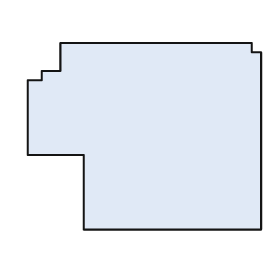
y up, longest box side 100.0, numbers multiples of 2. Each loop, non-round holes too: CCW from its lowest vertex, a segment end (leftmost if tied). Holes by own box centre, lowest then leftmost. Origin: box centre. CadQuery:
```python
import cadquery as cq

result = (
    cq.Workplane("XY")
    .moveTo(-26.0, -40.0)
    .lineTo(50.0, -40.0)
    .lineTo(50.0, 36.0)
    .lineTo(46.0, 36.0)
    .lineTo(46.0, 40.0)
    .lineTo(-36.0, 40.0)
    .lineTo(-36.0, 28.0)
    .lineTo(-44.0, 28.0)
    .lineTo(-44.0, 24.0)
    .lineTo(-50.0, 24.0)
    .lineTo(-50.0, -8.0)
    .lineTo(-26.0, -8.0)
    .close()
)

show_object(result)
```